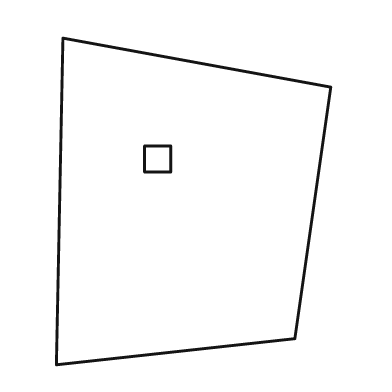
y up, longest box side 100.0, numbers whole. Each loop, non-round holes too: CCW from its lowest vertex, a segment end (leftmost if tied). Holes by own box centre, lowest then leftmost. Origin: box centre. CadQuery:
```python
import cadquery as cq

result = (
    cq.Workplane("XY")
    .moveTo(-42.0, -50.0)
    .lineTo(31.0, -42.0)
    .lineTo(42.0, 35.0)
    .lineTo(-40.0, 50.0)
    .close()
    .moveTo(-15.0, 9.0)
    .lineTo(-7.0, 9.0)
    .lineTo(-7.0, 17.0)
    .lineTo(-15.0, 17.0)
    .close()
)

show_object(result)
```